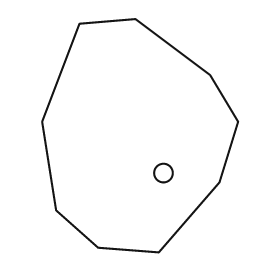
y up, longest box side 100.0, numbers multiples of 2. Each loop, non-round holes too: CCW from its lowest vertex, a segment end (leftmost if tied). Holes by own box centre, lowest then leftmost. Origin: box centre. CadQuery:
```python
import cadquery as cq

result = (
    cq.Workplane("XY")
    .moveTo(8.0, -50.0)
    .lineTo(34.0, -20.0)
    .lineTo(42.0, 6.0)
    .lineTo(30.0, 26.0)
    .lineTo(-2.0, 50.0)
    .lineTo(-26.0, 48.0)
    .lineTo(-42.0, 6.0)
    .lineTo(-36.0, -32.0)
    .lineTo(-18.0, -48.0)
    .close()
    .moveTo(10.0, -16.0)
    .circle(4.0)
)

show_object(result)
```